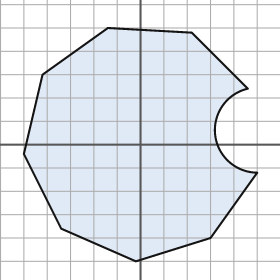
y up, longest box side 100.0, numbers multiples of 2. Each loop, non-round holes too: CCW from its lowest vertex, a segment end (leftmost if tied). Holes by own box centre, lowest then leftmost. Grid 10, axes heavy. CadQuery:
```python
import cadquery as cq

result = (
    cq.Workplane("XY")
    .moveTo(-2.0, -50.0)
    .lineTo(30.0, -40.0)
    .lineTo(50.0, -12.0)
    .threePointArc((32.0, 4.0), (46.0, 24.0))
    .lineTo(22.0, 48.0)
    .lineTo(-14.0, 50.0)
    .lineTo(-42.0, 30.0)
    .lineTo(-50.0, -4.0)
    .lineTo(-34.0, -36.0)
    .close()
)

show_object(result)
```